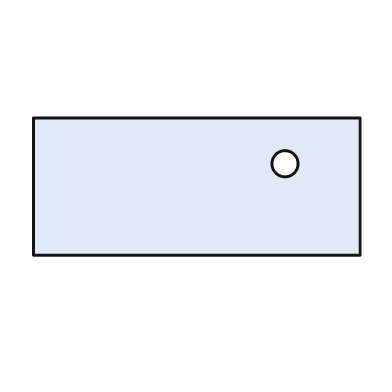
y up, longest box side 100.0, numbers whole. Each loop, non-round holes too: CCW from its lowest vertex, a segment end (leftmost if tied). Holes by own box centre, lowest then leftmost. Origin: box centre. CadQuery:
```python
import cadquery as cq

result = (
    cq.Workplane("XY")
    .moveTo(-50.0, -21.0)
    .lineTo(50.0, -21.0)
    .lineTo(50.0, 21.0)
    .lineTo(-50.0, 21.0)
    .close()
    .moveTo(27.0, 7.0)
    .circle(4.0)
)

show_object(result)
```